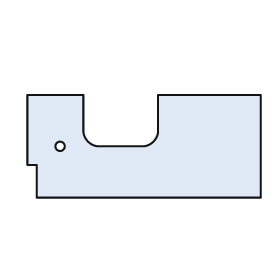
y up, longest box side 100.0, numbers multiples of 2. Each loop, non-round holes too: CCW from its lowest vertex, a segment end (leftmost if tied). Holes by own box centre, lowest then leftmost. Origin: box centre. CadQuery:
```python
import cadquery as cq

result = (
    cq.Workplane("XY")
    .moveTo(-46.0, -22.0)
    .lineTo(50.0, -22.0)
    .lineTo(50.0, 22.0)
    .lineTo(6.0, 22.0)
    .lineTo(6.0, 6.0)
    .threePointArc((4.0, 2.0), (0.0, 0.0))
    .lineTo(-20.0, 0.0)
    .threePointArc((-24.0, 2.0), (-26.0, 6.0))
    .lineTo(-26.0, 22.0)
    .lineTo(-50.0, 22.0)
    .lineTo(-50.0, -8.0)
    .lineTo(-46.0, -8.0)
    .close()
    .moveTo(-36.0, 0.0)
    .circle(2.0)
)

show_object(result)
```